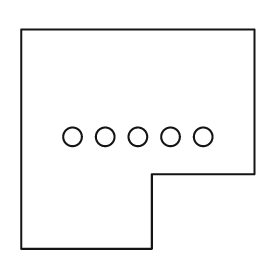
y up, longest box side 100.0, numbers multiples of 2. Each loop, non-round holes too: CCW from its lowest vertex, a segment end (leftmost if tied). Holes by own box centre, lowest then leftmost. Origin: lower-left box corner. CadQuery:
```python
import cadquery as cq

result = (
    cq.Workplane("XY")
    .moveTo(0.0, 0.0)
    .lineTo(56.0, 0.0)
    .lineTo(56.0, 32.0)
    .lineTo(100.0, 32.0)
    .lineTo(100.0, 94.0)
    .lineTo(0.0, 94.0)
    .close()
    .moveTo(22.0, 48.0)
    .circle(4.0)
    .moveTo(36.0, 48.0)
    .circle(4.0)
    .moveTo(50.0, 48.0)
    .circle(4.0)
    .moveTo(64.0, 48.0)
    .circle(4.0)
    .moveTo(78.0, 48.0)
    .circle(4.0)
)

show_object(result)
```